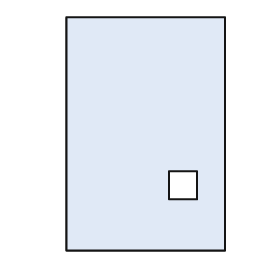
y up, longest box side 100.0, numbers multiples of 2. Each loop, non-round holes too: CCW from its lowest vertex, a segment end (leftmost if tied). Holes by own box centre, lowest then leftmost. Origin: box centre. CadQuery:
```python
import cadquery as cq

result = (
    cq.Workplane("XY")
    .moveTo(-34.0, -50.0)
    .lineTo(34.0, -50.0)
    .lineTo(34.0, 50.0)
    .lineTo(-34.0, 50.0)
    .close()
    .moveTo(10.0, -28.0)
    .lineTo(22.0, -28.0)
    .lineTo(22.0, -16.0)
    .lineTo(10.0, -16.0)
    .close()
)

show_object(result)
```